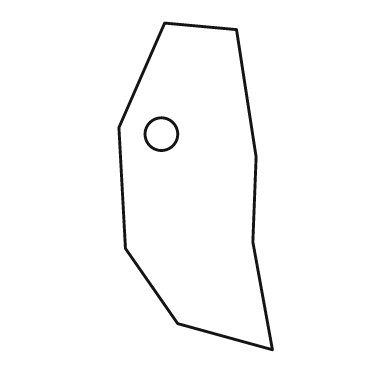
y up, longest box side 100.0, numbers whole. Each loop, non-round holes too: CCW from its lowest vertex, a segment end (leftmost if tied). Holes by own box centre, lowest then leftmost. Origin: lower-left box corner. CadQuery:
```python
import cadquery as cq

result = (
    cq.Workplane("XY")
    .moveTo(47.0, 0.0)
    .lineTo(41.0, 33.0)
    .lineTo(42.0, 59.0)
    .lineTo(36.0, 98.0)
    .lineTo(14.0, 100.0)
    .lineTo(0.0, 68.0)
    .lineTo(2.0, 31.0)
    .lineTo(18.0, 8.0)
    .close()
    .moveTo(13.0, 66.0)
    .circle(5.0)
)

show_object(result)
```